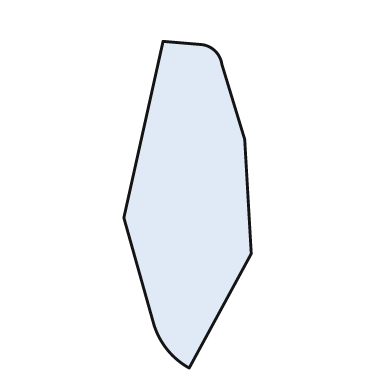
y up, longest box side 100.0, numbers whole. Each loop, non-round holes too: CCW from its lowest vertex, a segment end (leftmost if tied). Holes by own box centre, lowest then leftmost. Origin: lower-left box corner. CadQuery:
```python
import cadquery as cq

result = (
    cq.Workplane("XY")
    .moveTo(20.0, 0.0)
    .lineTo(39.0, 35.0)
    .lineTo(37.0, 70.0)
    .lineTo(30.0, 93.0)
    .threePointArc((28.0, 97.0), (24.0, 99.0))
    .lineTo(12.0, 100.0)
    .lineTo(0.0, 46.0)
    .lineTo(9.0, 14.0)
    .threePointArc((13.0, 6.0), (20.0, 0.0))
    .close()
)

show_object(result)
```